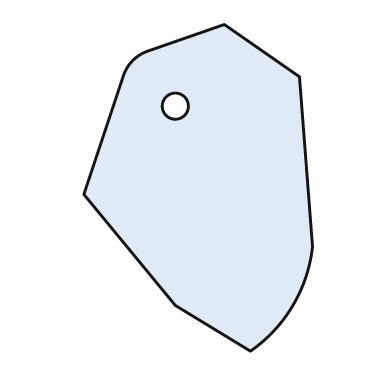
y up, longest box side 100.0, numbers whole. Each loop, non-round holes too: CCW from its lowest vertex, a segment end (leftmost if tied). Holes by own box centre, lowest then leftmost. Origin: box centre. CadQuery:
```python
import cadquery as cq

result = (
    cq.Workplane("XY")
    .moveTo(16.0, -50.0)
    .threePointArc((29.0, -36.0), (35.0, -18.0))
    .lineTo(31.0, 34.0)
    .lineTo(8.0, 50.0)
    .lineTo(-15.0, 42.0)
    .threePointArc((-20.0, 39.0), (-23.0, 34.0))
    .lineTo(-35.0, -2.0)
    .lineTo(-7.0, -36.0)
    .close()
    .moveTo(-7.0, 25.0)
    .circle(4.0)
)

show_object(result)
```